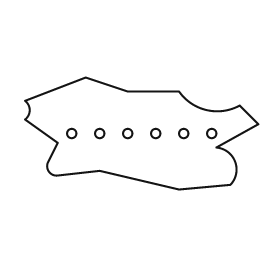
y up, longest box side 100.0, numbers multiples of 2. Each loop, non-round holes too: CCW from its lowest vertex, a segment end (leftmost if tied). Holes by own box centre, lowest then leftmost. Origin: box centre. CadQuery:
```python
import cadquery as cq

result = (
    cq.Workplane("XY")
    .moveTo(16.0, -24.0)
    .lineTo(38.0, -22.0)
    .threePointArc((40.0, -12.0), (32.0, -6.0))
    .lineTo(50.0, 4.0)
    .lineTo(42.0, 12.0)
    .threePointArc((28.0, 10.0), (16.0, 18.0))
    .lineTo(-6.0, 18.0)
    .lineTo(-24.0, 24.0)
    .lineTo(-50.0, 14.0)
    .threePointArc((-48.0, 10.0), (-50.0, 6.0))
    .lineTo(-36.0, -4.0)
    .lineTo(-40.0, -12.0)
    .threePointArc((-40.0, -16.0), (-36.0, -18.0))
    .lineTo(-18.0, -16.0)
    .close()
    .moveTo(-30.0, 0.0)
    .circle(2.0)
    .moveTo(-18.0, 0.0)
    .circle(2.0)
    .moveTo(-6.0, 0.0)
    .circle(2.0)
    .moveTo(6.0, 0.0)
    .circle(2.0)
    .moveTo(18.0, 0.0)
    .circle(2.0)
    .moveTo(30.0, 0.0)
    .circle(2.0)
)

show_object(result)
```